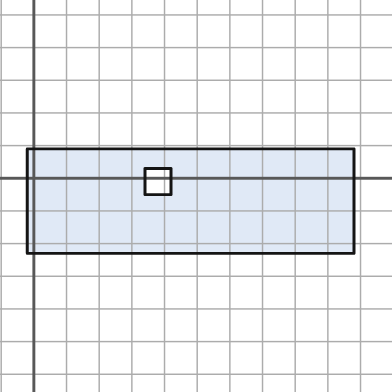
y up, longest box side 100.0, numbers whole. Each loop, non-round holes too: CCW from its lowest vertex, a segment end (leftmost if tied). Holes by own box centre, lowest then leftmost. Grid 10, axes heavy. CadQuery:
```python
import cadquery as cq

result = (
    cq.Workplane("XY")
    .moveTo(-2.0, -23.0)
    .lineTo(98.0, -23.0)
    .lineTo(98.0, 9.0)
    .lineTo(-2.0, 9.0)
    .close()
    .moveTo(34.0, -5.0)
    .lineTo(42.0, -5.0)
    .lineTo(42.0, 3.0)
    .lineTo(34.0, 3.0)
    .close()
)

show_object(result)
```